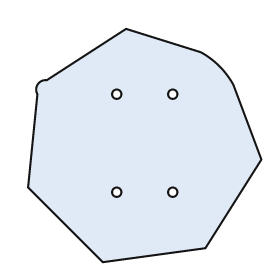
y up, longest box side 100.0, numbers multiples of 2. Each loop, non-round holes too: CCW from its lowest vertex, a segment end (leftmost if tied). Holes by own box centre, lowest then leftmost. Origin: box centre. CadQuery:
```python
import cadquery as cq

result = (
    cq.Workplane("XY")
    .moveTo(-18.0, -50.0)
    .lineTo(26.0, -44.0)
    .lineTo(50.0, -6.0)
    .lineTo(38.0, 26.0)
    .threePointArc((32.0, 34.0), (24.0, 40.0))
    .lineTo(-8.0, 50.0)
    .lineTo(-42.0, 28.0)
    .threePointArc((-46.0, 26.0), (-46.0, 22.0))
    .lineTo(-50.0, -18.0)
    .close()
    .moveTo(-12.0, -20.0)
    .circle(2.0)
    .moveTo(12.0, -20.0)
    .circle(2.0)
    .moveTo(-12.0, 22.0)
    .circle(2.0)
    .moveTo(12.0, 22.0)
    .circle(2.0)
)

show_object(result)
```